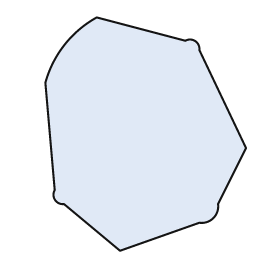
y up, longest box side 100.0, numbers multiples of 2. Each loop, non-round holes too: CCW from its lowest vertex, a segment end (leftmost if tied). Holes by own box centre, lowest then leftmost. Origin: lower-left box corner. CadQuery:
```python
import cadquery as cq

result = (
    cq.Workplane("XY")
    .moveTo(32.0, 0.0)
    .lineTo(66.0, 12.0)
    .threePointArc((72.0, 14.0), (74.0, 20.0))
    .lineTo(86.0, 44.0)
    .lineTo(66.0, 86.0)
    .threePointArc((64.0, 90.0), (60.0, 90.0))
    .lineTo(22.0, 100.0)
    .threePointArc((8.0, 88.0), (0.0, 72.0))
    .lineTo(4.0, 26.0)
    .threePointArc((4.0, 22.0), (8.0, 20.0))
    .close()
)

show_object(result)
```